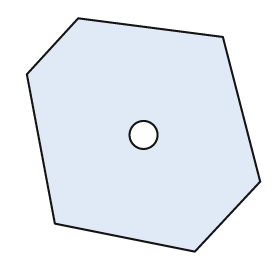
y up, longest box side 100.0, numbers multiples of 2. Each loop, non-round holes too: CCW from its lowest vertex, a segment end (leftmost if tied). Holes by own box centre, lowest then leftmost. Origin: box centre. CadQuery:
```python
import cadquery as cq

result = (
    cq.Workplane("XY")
    .moveTo(22.0, -50.0)
    .lineTo(50.0, -20.0)
    .lineTo(34.0, 42.0)
    .lineTo(-28.0, 50.0)
    .lineTo(-50.0, 26.0)
    .lineTo(-38.0, -38.0)
    .close()
    .moveTo(0.0, 0.0)
    .circle(6.0)
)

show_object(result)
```